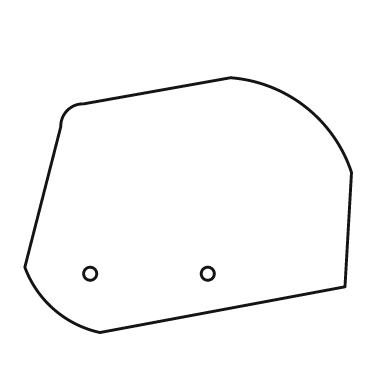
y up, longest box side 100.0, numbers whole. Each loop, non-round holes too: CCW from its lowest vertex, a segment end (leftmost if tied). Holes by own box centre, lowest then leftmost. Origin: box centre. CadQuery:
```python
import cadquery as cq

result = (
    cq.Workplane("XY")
    .moveTo(-27.0, -39.0)
    .lineTo(48.0, -25.0)
    .lineTo(50.0, 10.0)
    .threePointArc((36.0, 30.0), (13.0, 39.0))
    .lineTo(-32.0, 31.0)
    .threePointArc((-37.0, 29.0), (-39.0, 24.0))
    .lineTo(-50.0, -19.0)
    .threePointArc((-41.0, -32.0), (-27.0, -39.0))
    .close()
    .moveTo(-30.0, -21.0)
    .circle(2.0)
    .moveTo(6.0, -21.0)
    .circle(2.0)
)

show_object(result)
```